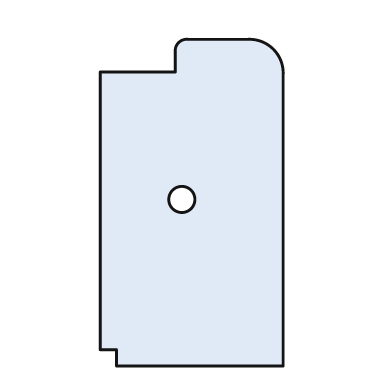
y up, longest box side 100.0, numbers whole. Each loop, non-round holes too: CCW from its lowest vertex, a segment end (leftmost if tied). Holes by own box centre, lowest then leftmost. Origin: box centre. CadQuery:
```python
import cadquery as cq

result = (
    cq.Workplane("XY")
    .moveTo(-23.0, -50.0)
    .lineTo(28.0, -50.0)
    .lineTo(28.0, 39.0)
    .threePointArc((25.0, 47.0), (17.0, 50.0))
    .lineTo(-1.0, 50.0)
    .threePointArc((-4.0, 49.0), (-5.0, 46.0))
    .lineTo(-5.0, 40.0)
    .lineTo(-28.0, 40.0)
    .lineTo(-28.0, -45.0)
    .lineTo(-23.0, -45.0)
    .close()
    .moveTo(-3.0, 1.0)
    .circle(4.0)
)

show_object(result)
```